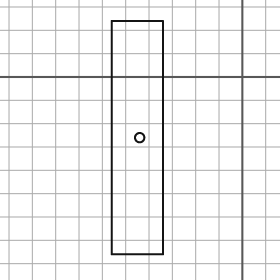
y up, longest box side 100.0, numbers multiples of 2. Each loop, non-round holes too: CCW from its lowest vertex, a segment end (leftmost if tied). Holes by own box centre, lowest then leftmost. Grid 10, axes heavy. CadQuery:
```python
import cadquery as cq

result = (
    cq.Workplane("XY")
    .moveTo(-56.0, -76.0)
    .lineTo(-34.0, -76.0)
    .lineTo(-34.0, 24.0)
    .lineTo(-56.0, 24.0)
    .close()
    .moveTo(-44.0, -26.0)
    .circle(2.0)
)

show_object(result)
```